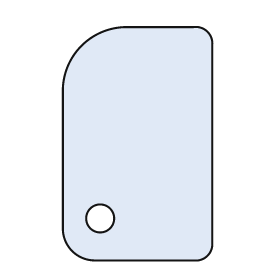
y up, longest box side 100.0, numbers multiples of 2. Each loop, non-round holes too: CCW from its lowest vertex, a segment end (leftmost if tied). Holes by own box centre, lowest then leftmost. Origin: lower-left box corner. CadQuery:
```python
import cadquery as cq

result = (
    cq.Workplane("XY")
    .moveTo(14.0, 0.0)
    .lineTo(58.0, 0.0)
    .threePointArc((62.0, 2.0), (64.0, 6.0))
    .lineTo(64.0, 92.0)
    .threePointArc((62.0, 98.0), (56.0, 100.0))
    .lineTo(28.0, 100.0)
    .threePointArc((8.0, 92.0), (0.0, 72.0))
    .lineTo(0.0, 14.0)
    .threePointArc((4.0, 4.0), (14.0, 0.0))
    .close()
    .moveTo(16.0, 18.0)
    .circle(6.0)
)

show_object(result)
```